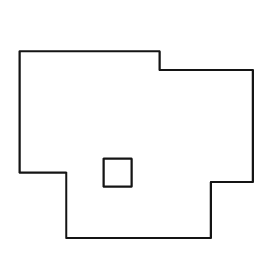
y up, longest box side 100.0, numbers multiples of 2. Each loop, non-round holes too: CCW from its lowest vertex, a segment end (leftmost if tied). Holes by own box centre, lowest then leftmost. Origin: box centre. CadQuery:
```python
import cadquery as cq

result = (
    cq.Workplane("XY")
    .moveTo(-30.0, -40.0)
    .lineTo(32.0, -40.0)
    .lineTo(32.0, -16.0)
    .lineTo(50.0, -16.0)
    .lineTo(50.0, 32.0)
    .lineTo(10.0, 32.0)
    .lineTo(10.0, 40.0)
    .lineTo(-50.0, 40.0)
    .lineTo(-50.0, -12.0)
    .lineTo(-30.0, -12.0)
    .close()
    .moveTo(-14.0, -18.0)
    .lineTo(-2.0, -18.0)
    .lineTo(-2.0, -6.0)
    .lineTo(-14.0, -6.0)
    .close()
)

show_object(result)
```